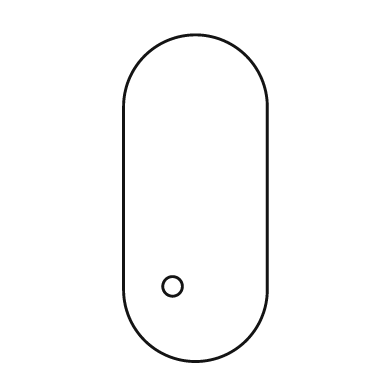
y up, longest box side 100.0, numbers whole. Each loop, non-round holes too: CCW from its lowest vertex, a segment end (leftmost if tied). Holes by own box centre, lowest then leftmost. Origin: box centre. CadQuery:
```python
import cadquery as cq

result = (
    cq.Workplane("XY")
    .moveTo(-22.0, -28.0)
    .threePointArc((0.0, -50.0), (22.0, -28.0))
    .lineTo(22.0, 28.0)
    .threePointArc((0.0, 50.0), (-22.0, 28.0))
    .close()
    .moveTo(-7.0, -27.0)
    .circle(3.0)
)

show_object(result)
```